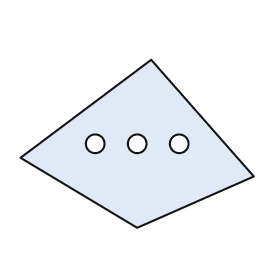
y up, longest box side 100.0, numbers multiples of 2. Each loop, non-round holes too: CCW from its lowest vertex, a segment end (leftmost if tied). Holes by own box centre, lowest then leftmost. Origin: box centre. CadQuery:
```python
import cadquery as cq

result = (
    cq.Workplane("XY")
    .moveTo(0.0, -36.0)
    .lineTo(50.0, -14.0)
    .lineTo(6.0, 36.0)
    .lineTo(-50.0, -6.0)
    .close()
    .moveTo(-18.0, 0.0)
    .circle(4.0)
    .moveTo(0.0, 0.0)
    .circle(4.0)
    .moveTo(18.0, 0.0)
    .circle(4.0)
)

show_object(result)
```